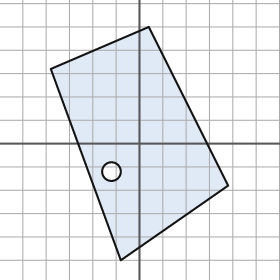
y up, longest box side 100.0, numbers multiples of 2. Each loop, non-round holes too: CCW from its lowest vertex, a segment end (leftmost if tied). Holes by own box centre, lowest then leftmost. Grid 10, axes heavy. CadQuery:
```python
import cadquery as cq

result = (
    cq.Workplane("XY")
    .moveTo(-8.0, -50.0)
    .lineTo(38.0, -18.0)
    .lineTo(4.0, 50.0)
    .lineTo(-38.0, 32.0)
    .close()
    .moveTo(-12.0, -12.0)
    .circle(4.0)
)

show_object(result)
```